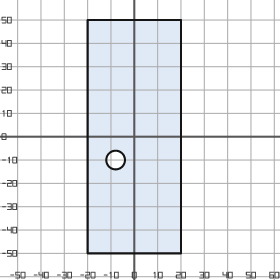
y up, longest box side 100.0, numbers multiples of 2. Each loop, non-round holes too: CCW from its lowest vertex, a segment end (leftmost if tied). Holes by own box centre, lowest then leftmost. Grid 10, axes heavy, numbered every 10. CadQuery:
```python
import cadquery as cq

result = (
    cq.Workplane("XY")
    .moveTo(-20.0, -50.0)
    .lineTo(20.0, -50.0)
    .lineTo(20.0, 50.0)
    .lineTo(-20.0, 50.0)
    .close()
    .moveTo(-8.0, -10.0)
    .circle(4.0)
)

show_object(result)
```